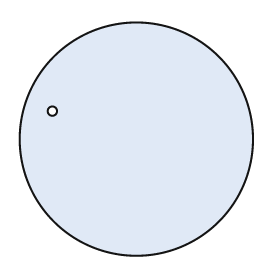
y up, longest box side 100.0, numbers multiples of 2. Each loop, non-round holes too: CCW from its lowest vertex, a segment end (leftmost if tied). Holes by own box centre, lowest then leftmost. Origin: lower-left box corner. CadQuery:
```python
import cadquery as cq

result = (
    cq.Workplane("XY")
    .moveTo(50.0, 50.0)
    .circle(50.0)
    .moveTo(14.0, 62.0)
    .circle(2.0)
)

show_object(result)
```